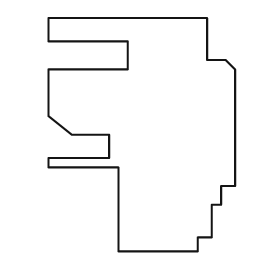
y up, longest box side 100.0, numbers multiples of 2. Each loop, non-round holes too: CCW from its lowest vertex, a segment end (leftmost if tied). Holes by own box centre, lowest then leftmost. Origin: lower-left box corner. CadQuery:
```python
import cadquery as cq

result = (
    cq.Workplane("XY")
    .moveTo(30.0, 0.0)
    .lineTo(64.0, 0.0)
    .lineTo(64.0, 6.0)
    .lineTo(70.0, 6.0)
    .lineTo(70.0, 20.0)
    .lineTo(74.0, 20.0)
    .lineTo(74.0, 28.0)
    .lineTo(80.0, 28.0)
    .lineTo(80.0, 78.0)
    .lineTo(76.0, 82.0)
    .lineTo(68.0, 82.0)
    .lineTo(68.0, 100.0)
    .lineTo(0.0, 100.0)
    .lineTo(0.0, 90.0)
    .lineTo(34.0, 90.0)
    .lineTo(34.0, 78.0)
    .lineTo(0.0, 78.0)
    .lineTo(0.0, 58.0)
    .lineTo(10.0, 50.0)
    .lineTo(26.0, 50.0)
    .lineTo(26.0, 40.0)
    .lineTo(0.0, 40.0)
    .lineTo(0.0, 36.0)
    .lineTo(30.0, 36.0)
    .close()
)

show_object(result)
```